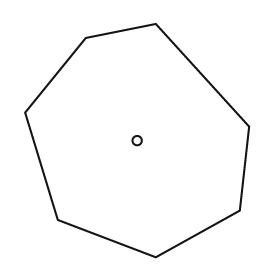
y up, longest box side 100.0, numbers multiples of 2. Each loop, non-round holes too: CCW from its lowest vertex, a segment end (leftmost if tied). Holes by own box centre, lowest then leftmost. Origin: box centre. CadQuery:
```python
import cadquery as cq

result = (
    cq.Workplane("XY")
    .moveTo(8.0, -50.0)
    .lineTo(44.0, -30.0)
    .lineTo(48.0, 6.0)
    .lineTo(8.0, 50.0)
    .lineTo(-22.0, 44.0)
    .lineTo(-48.0, 12.0)
    .lineTo(-34.0, -34.0)
    .close()
    .moveTo(0.0, 0.0)
    .circle(2.0)
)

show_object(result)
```